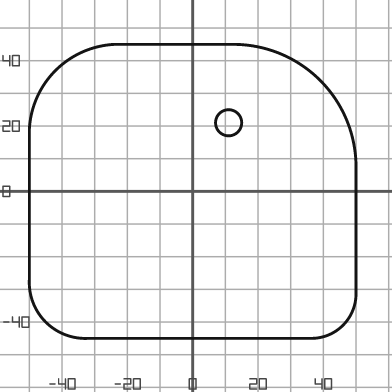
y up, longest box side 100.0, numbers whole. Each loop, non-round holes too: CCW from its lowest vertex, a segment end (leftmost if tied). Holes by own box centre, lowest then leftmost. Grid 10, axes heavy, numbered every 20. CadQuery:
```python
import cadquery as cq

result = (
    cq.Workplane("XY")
    .moveTo(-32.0, -45.0)
    .lineTo(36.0, -45.0)
    .threePointArc((46.0, -41.0), (50.0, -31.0))
    .lineTo(50.0, 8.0)
    .threePointArc((39.0, 34.0), (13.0, 45.0))
    .lineTo(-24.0, 45.0)
    .threePointArc((-42.0, 37.0), (-50.0, 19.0))
    .lineTo(-50.0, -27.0)
    .threePointArc((-45.0, -40.0), (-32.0, -45.0))
    .close()
    .moveTo(11.0, 21.0)
    .circle(4.0)
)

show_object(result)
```